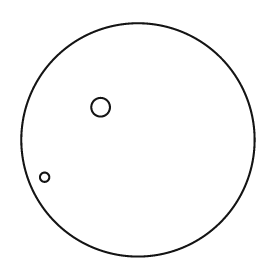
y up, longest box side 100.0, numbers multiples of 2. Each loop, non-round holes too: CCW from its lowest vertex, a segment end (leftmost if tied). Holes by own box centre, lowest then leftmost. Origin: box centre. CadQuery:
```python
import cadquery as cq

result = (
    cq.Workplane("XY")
    .moveTo(0.0, 0.0)
    .circle(50.0)
    .moveTo(-40.0, -16.0)
    .circle(2.0)
    .moveTo(-16.0, 14.0)
    .circle(4.0)
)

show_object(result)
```